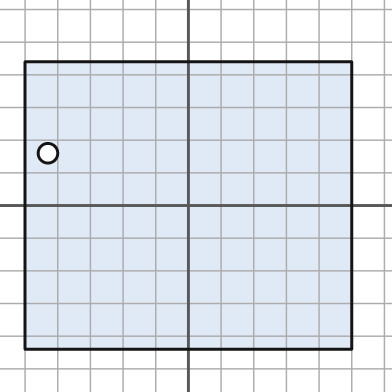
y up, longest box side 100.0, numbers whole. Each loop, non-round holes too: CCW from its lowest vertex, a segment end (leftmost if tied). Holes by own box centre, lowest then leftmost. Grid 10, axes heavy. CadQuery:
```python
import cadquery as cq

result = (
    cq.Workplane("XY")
    .moveTo(-50.0, -44.0)
    .lineTo(50.0, -44.0)
    .lineTo(50.0, 44.0)
    .lineTo(-50.0, 44.0)
    .close()
    .moveTo(-43.0, 16.0)
    .circle(3.0)
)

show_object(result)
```